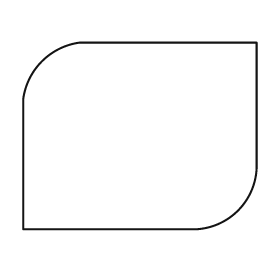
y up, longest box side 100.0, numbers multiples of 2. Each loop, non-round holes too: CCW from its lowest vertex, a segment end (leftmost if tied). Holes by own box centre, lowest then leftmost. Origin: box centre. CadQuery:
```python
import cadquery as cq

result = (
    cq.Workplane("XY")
    .moveTo(-50.0, -40.0)
    .lineTo(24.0, -40.0)
    .threePointArc((42.0, -32.0), (50.0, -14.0))
    .lineTo(50.0, 40.0)
    .lineTo(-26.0, 40.0)
    .threePointArc((-42.0, 32.0), (-50.0, 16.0))
    .close()
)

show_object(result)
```